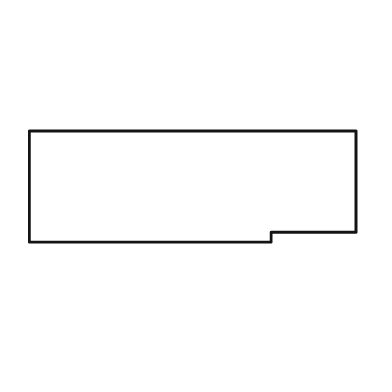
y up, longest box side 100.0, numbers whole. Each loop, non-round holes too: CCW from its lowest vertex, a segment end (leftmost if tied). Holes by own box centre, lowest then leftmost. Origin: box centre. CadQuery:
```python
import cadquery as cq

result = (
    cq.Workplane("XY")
    .moveTo(-50.0, -17.0)
    .lineTo(24.0, -17.0)
    .lineTo(24.0, -14.0)
    .lineTo(50.0, -14.0)
    .lineTo(50.0, 17.0)
    .lineTo(-50.0, 17.0)
    .close()
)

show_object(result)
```